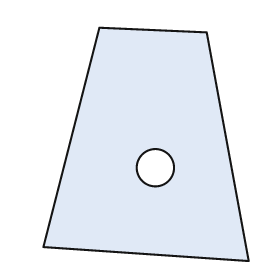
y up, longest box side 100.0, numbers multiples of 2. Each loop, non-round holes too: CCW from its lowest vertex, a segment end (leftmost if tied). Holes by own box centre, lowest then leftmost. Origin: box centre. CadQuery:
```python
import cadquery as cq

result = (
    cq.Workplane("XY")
    .moveTo(44.0, -50.0)
    .lineTo(26.0, 48.0)
    .lineTo(-20.0, 50.0)
    .lineTo(-44.0, -44.0)
    .close()
    .moveTo(4.0, -10.0)
    .circle(8.0)
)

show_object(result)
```